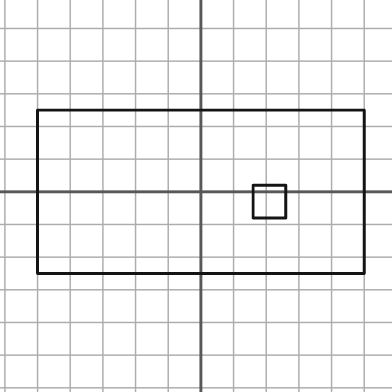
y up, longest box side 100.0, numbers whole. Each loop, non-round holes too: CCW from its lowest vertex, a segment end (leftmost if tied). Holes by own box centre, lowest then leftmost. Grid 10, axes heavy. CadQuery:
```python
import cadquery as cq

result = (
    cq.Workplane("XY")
    .moveTo(-50.0, -25.0)
    .lineTo(50.0, -25.0)
    .lineTo(50.0, 25.0)
    .lineTo(-50.0, 25.0)
    .close()
    .moveTo(16.0, -8.0)
    .lineTo(26.0, -8.0)
    .lineTo(26.0, 2.0)
    .lineTo(16.0, 2.0)
    .close()
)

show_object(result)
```